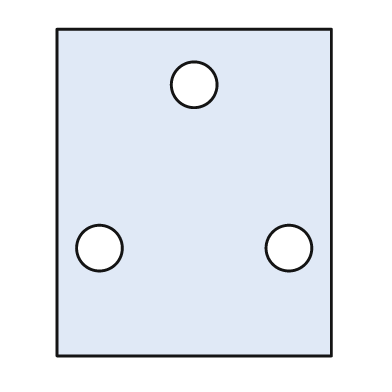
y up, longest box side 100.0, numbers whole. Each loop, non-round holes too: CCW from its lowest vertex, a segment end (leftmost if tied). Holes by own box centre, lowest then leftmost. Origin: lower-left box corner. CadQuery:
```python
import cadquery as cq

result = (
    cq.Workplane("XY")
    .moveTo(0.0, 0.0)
    .lineTo(84.0, 0.0)
    .lineTo(84.0, 100.0)
    .lineTo(0.0, 100.0)
    .close()
    .moveTo(13.0, 33.0)
    .circle(7.0)
    .moveTo(71.0, 33.0)
    .circle(7.0)
    .moveTo(42.0, 83.0)
    .circle(7.0)
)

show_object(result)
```